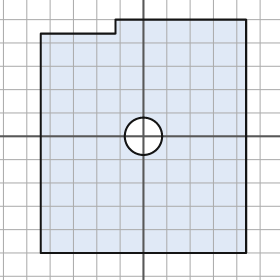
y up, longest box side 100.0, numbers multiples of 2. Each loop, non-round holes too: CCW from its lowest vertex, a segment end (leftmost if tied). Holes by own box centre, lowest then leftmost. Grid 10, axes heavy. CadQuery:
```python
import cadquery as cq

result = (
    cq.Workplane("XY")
    .moveTo(-44.0, -50.0)
    .lineTo(44.0, -50.0)
    .lineTo(44.0, 50.0)
    .lineTo(-12.0, 50.0)
    .lineTo(-12.0, 44.0)
    .lineTo(-44.0, 44.0)
    .close()
    .moveTo(0.0, 0.0)
    .circle(8.0)
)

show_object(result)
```